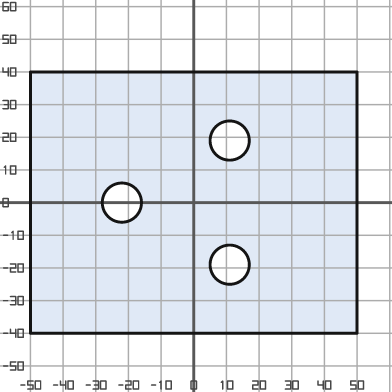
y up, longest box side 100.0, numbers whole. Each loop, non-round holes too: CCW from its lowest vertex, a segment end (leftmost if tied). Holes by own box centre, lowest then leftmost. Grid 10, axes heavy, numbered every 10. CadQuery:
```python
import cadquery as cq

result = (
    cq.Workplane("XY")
    .moveTo(-50.0, -40.0)
    .lineTo(50.0, -40.0)
    .lineTo(50.0, 40.0)
    .lineTo(-50.0, 40.0)
    .close()
    .moveTo(11.0, -19.0)
    .circle(6.0)
    .moveTo(-22.0, 0.0)
    .circle(6.0)
    .moveTo(11.0, 19.0)
    .circle(6.0)
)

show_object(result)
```